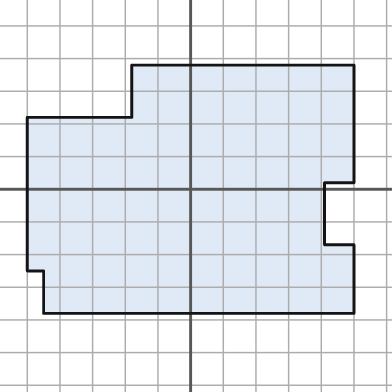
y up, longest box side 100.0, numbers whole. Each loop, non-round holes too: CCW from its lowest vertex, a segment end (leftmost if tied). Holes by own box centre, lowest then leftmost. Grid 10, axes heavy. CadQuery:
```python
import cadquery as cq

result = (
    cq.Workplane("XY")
    .moveTo(-45.0, -38.0)
    .lineTo(50.0, -38.0)
    .lineTo(50.0, -17.0)
    .lineTo(41.0, -17.0)
    .lineTo(41.0, 2.0)
    .lineTo(50.0, 2.0)
    .lineTo(50.0, 38.0)
    .lineTo(-18.0, 38.0)
    .lineTo(-18.0, 22.0)
    .lineTo(-50.0, 22.0)
    .lineTo(-50.0, -25.0)
    .lineTo(-45.0, -25.0)
    .close()
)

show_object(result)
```